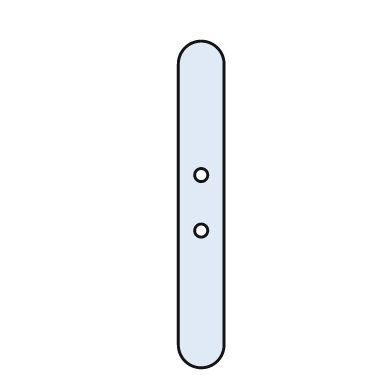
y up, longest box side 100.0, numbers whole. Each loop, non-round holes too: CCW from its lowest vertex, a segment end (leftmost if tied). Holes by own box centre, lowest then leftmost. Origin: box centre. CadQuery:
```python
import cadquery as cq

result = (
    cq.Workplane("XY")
    .moveTo(-7.0, -43.0)
    .threePointArc((0.0, -50.0), (7.0, -43.0))
    .lineTo(7.0, 43.0)
    .threePointArc((0.0, 50.0), (-7.0, 43.0))
    .close()
    .moveTo(0.0, -8.0)
    .circle(2.0)
    .moveTo(0.0, 9.0)
    .circle(2.0)
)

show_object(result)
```